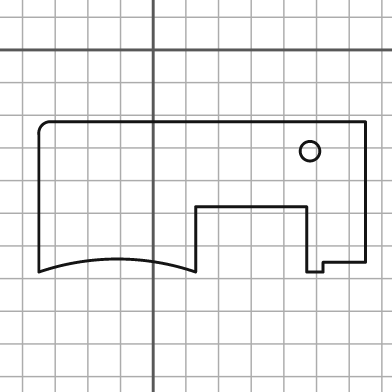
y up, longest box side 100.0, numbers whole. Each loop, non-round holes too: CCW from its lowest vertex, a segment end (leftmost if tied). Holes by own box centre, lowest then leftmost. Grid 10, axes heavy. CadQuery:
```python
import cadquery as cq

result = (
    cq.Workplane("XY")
    .moveTo(-35.0, -68.0)
    .threePointArc((-11.0, -64.0), (13.0, -68.0))
    .lineTo(13.0, -48.0)
    .lineTo(47.0, -48.0)
    .lineTo(47.0, -68.0)
    .lineTo(52.0, -68.0)
    .lineTo(52.0, -65.0)
    .lineTo(65.0, -65.0)
    .lineTo(65.0, -22.0)
    .lineTo(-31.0, -22.0)
    .threePointArc((-34.0, -23.0), (-35.0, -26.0))
    .close()
    .moveTo(48.0, -31.0)
    .circle(3.0)
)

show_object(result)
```